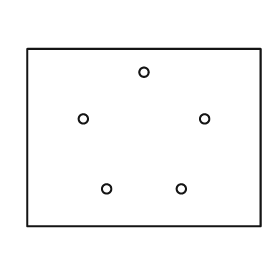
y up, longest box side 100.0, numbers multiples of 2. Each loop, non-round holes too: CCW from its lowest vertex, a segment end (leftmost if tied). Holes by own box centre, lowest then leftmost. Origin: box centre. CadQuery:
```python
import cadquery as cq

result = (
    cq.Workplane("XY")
    .moveTo(-50.0, -38.0)
    .lineTo(50.0, -38.0)
    .lineTo(50.0, 38.0)
    .lineTo(-50.0, 38.0)
    .close()
    .moveTo(-16.0, -22.0)
    .circle(2.0)
    .moveTo(16.0, -22.0)
    .circle(2.0)
    .moveTo(-26.0, 8.0)
    .circle(2.0)
    .moveTo(26.0, 8.0)
    .circle(2.0)
    .moveTo(0.0, 28.0)
    .circle(2.0)
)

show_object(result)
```